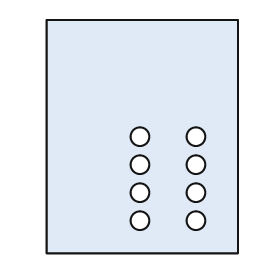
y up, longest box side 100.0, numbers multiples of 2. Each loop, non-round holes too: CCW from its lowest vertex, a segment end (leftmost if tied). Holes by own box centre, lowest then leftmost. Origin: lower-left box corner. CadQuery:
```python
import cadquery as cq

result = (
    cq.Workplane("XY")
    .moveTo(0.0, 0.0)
    .lineTo(82.0, 0.0)
    .lineTo(82.0, 100.0)
    .lineTo(0.0, 100.0)
    .close()
    .moveTo(40.0, 14.0)
    .circle(4.0)
    .moveTo(64.0, 14.0)
    .circle(4.0)
    .moveTo(40.0, 26.0)
    .circle(4.0)
    .moveTo(64.0, 26.0)
    .circle(4.0)
    .moveTo(40.0, 38.0)
    .circle(4.0)
    .moveTo(64.0, 38.0)
    .circle(4.0)
    .moveTo(40.0, 50.0)
    .circle(4.0)
    .moveTo(64.0, 50.0)
    .circle(4.0)
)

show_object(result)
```